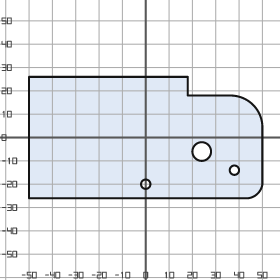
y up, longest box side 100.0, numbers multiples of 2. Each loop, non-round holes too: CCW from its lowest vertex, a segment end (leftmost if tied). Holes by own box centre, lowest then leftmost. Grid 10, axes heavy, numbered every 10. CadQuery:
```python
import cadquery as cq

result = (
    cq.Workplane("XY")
    .moveTo(-50.0, -26.0)
    .lineTo(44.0, -26.0)
    .threePointArc((48.0, -24.0), (50.0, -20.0))
    .lineTo(50.0, 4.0)
    .threePointArc((46.0, 14.0), (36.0, 18.0))
    .lineTo(18.0, 18.0)
    .lineTo(18.0, 26.0)
    .lineTo(-50.0, 26.0)
    .close()
    .moveTo(0.0, -20.0)
    .circle(2.0)
    .moveTo(38.0, -14.0)
    .circle(2.0)
    .moveTo(24.0, -6.0)
    .circle(4.0)
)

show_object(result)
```